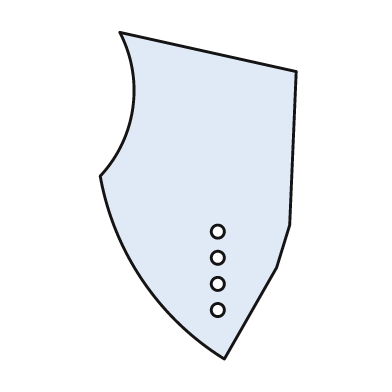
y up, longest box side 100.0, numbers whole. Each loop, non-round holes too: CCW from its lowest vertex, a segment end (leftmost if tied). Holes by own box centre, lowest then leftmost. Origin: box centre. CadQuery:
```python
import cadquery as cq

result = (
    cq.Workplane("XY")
    .moveTo(8.0, -50.0)
    .lineTo(24.0, -22.0)
    .lineTo(28.0, -9.0)
    .lineTo(30.0, 38.0)
    .lineTo(-24.0, 50.0)
    .threePointArc((-20.0, 27.0), (-30.0, 6.0))
    .threePointArc((-17.0, -26.0), (8.0, -50.0))
    .close()
    .moveTo(6.0, -35.0)
    .circle(2.0)
    .moveTo(6.0, -27.0)
    .circle(2.0)
    .moveTo(6.0, -19.0)
    .circle(2.0)
    .moveTo(6.0, -11.0)
    .circle(2.0)
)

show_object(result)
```